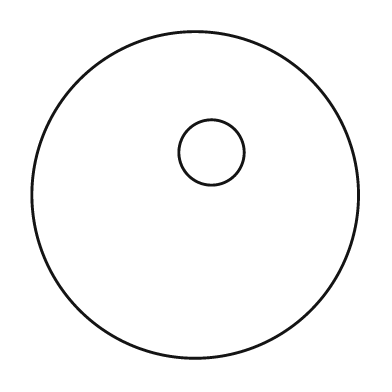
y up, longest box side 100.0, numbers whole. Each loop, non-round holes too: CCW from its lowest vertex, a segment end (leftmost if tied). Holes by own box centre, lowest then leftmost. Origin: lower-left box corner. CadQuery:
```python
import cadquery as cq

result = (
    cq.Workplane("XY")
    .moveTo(50.0, 50.0)
    .circle(50.0)
    .moveTo(55.0, 63.0)
    .circle(10.0)
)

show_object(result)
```